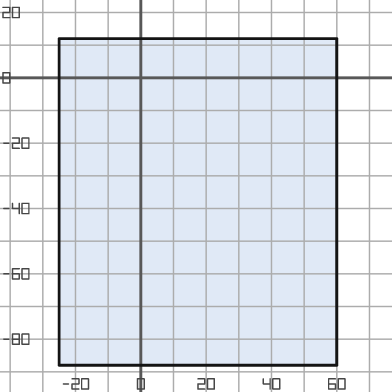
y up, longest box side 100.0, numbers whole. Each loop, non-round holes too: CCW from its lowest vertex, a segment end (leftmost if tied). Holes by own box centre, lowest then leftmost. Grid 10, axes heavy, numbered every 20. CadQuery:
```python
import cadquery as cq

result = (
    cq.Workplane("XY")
    .moveTo(-25.0, -88.0)
    .lineTo(60.0, -88.0)
    .lineTo(60.0, 12.0)
    .lineTo(-25.0, 12.0)
    .close()
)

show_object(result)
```